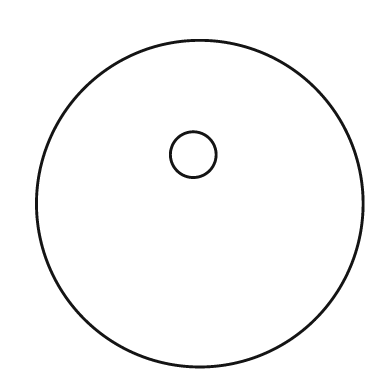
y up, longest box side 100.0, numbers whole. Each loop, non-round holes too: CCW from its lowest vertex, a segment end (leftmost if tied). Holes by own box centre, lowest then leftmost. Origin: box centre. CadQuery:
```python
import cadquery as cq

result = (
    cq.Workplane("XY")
    .moveTo(0.0, 0.0)
    .circle(50.0)
    .moveTo(-2.0, 15.0)
    .circle(7.0)
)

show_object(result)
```